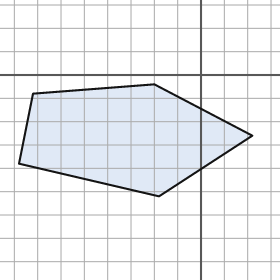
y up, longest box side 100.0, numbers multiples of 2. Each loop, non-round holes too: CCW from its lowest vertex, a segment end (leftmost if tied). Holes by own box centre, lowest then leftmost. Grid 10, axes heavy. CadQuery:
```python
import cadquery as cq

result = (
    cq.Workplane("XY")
    .moveTo(-18.0, -52.0)
    .lineTo(22.0, -26.0)
    .lineTo(-20.0, -4.0)
    .lineTo(-72.0, -8.0)
    .lineTo(-78.0, -38.0)
    .close()
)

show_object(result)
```